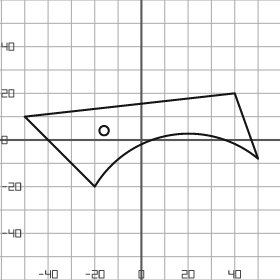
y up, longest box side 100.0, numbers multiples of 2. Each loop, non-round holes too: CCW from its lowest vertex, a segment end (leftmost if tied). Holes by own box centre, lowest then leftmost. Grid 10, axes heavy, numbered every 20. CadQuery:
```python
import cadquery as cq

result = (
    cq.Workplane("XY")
    .moveTo(-20.0, -20.0)
    .threePointArc((12.0, 2.0), (50.0, -8.0))
    .lineTo(40.0, 20.0)
    .lineTo(-50.0, 10.0)
    .close()
    .moveTo(-16.0, 4.0)
    .circle(2.0)
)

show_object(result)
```